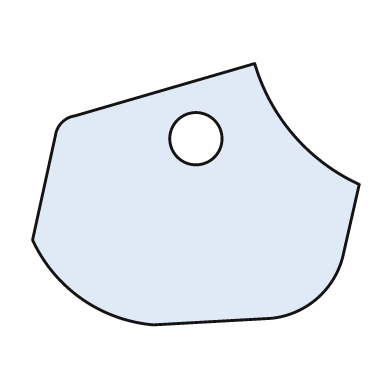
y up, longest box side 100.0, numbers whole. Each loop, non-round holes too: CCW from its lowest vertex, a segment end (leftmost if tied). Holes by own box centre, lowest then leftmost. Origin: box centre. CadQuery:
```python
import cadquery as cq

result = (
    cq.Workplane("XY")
    .moveTo(-13.0, -40.0)
    .lineTo(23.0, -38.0)
    .threePointArc((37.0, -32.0), (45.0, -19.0))
    .lineTo(50.0, 3.0)
    .threePointArc((30.0, 18.0), (18.0, 40.0))
    .lineTo(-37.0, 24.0)
    .threePointArc((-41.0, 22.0), (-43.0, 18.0))
    .lineTo(-50.0, -14.0)
    .threePointArc((-35.0, -32.0), (-13.0, -40.0))
    .close()
    .moveTo(0.0, 17.0)
    .circle(8.0)
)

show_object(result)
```